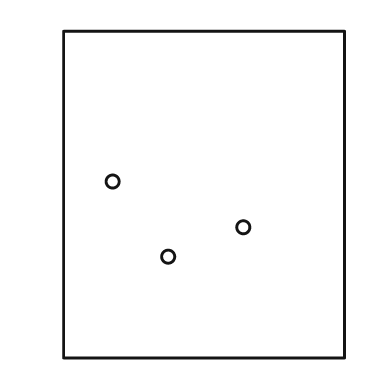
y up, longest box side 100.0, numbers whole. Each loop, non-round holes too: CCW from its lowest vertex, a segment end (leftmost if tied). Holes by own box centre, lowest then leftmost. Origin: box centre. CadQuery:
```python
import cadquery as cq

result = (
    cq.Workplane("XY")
    .moveTo(-43.0, -50.0)
    .lineTo(43.0, -50.0)
    .lineTo(43.0, 50.0)
    .lineTo(-43.0, 50.0)
    .close()
    .moveTo(-11.0, -19.0)
    .circle(2.0)
    .moveTo(12.0, -10.0)
    .circle(2.0)
    .moveTo(-28.0, 4.0)
    .circle(2.0)
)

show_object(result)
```